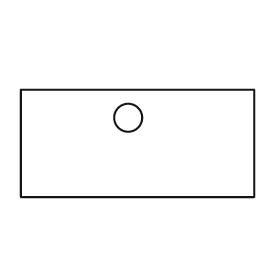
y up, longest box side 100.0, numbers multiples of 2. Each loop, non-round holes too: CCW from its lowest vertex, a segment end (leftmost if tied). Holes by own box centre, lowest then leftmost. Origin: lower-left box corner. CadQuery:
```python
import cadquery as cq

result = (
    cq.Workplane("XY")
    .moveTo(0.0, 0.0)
    .lineTo(100.0, 0.0)
    .lineTo(100.0, 46.0)
    .lineTo(0.0, 46.0)
    .close()
    .moveTo(46.0, 34.0)
    .circle(6.0)
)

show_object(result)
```